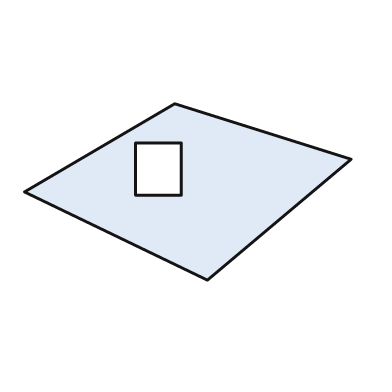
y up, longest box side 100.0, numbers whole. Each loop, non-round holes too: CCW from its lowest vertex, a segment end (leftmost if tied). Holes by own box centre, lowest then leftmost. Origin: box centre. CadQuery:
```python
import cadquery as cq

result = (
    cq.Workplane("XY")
    .moveTo(6.0, -27.0)
    .lineTo(50.0, 10.0)
    .lineTo(-4.0, 27.0)
    .lineTo(-50.0, 0.0)
    .close()
    .moveTo(-16.0, -1.0)
    .lineTo(-2.0, -1.0)
    .lineTo(-2.0, 15.0)
    .lineTo(-16.0, 15.0)
    .close()
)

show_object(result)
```